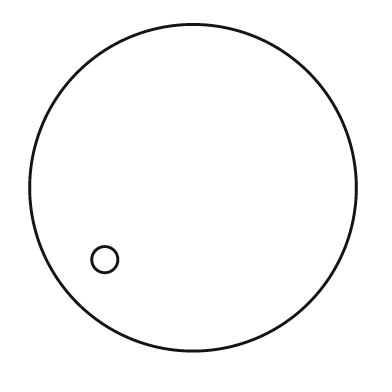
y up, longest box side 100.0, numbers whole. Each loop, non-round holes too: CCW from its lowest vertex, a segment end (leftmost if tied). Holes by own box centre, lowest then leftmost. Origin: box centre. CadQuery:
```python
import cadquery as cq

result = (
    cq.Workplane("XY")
    .moveTo(0.0, 0.0)
    .circle(50.0)
    .moveTo(-27.0, -22.0)
    .circle(4.0)
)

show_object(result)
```